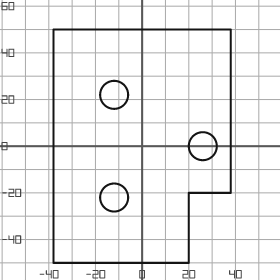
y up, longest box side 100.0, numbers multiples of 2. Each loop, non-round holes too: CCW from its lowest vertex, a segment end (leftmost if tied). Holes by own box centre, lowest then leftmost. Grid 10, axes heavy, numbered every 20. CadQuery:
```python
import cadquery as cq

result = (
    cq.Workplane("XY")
    .moveTo(-38.0, -50.0)
    .lineTo(20.0, -50.0)
    .lineTo(20.0, -20.0)
    .lineTo(38.0, -20.0)
    .lineTo(38.0, 50.0)
    .lineTo(-38.0, 50.0)
    .close()
    .moveTo(-12.0, -22.0)
    .circle(6.0)
    .moveTo(26.0, 0.0)
    .circle(6.0)
    .moveTo(-12.0, 22.0)
    .circle(6.0)
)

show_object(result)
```